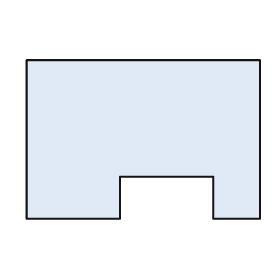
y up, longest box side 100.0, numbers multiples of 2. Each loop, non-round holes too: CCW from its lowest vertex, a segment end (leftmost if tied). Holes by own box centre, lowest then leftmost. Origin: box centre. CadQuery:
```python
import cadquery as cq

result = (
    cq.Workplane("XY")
    .moveTo(-50.0, -34.0)
    .lineTo(-10.0, -34.0)
    .lineTo(-10.0, -16.0)
    .lineTo(30.0, -16.0)
    .lineTo(30.0, -34.0)
    .lineTo(50.0, -34.0)
    .lineTo(50.0, 34.0)
    .lineTo(-50.0, 34.0)
    .close()
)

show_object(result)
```